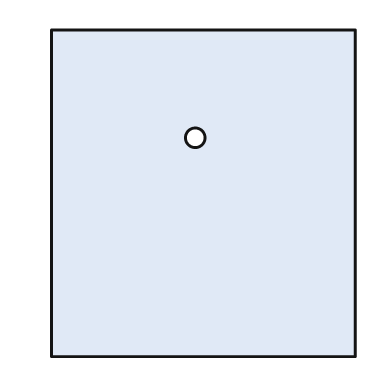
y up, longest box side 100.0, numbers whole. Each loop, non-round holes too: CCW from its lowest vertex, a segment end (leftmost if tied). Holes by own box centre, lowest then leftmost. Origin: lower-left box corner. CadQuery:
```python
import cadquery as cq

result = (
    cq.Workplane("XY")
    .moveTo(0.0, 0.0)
    .lineTo(93.0, 0.0)
    .lineTo(93.0, 100.0)
    .lineTo(0.0, 100.0)
    .close()
    .moveTo(44.0, 67.0)
    .circle(3.0)
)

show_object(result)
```